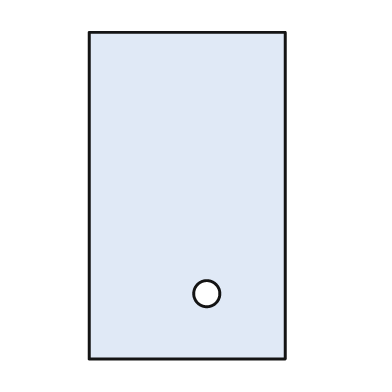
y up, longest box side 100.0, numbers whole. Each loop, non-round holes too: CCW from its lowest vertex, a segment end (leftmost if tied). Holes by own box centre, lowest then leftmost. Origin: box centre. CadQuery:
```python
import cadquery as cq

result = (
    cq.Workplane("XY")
    .moveTo(-30.0, -50.0)
    .lineTo(30.0, -50.0)
    .lineTo(30.0, 50.0)
    .lineTo(-30.0, 50.0)
    .close()
    .moveTo(6.0, -30.0)
    .circle(4.0)
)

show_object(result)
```